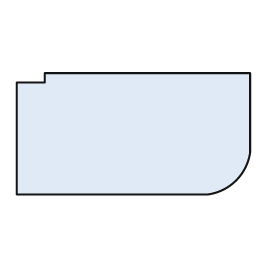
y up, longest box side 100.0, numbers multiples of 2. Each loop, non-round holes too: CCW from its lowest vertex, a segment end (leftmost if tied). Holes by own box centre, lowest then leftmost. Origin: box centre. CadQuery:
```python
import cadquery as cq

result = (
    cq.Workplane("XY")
    .moveTo(-50.0, -26.0)
    .lineTo(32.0, -26.0)
    .threePointArc((44.0, -20.0), (50.0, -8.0))
    .lineTo(50.0, 26.0)
    .lineTo(-38.0, 26.0)
    .lineTo(-38.0, 22.0)
    .lineTo(-50.0, 22.0)
    .close()
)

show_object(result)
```